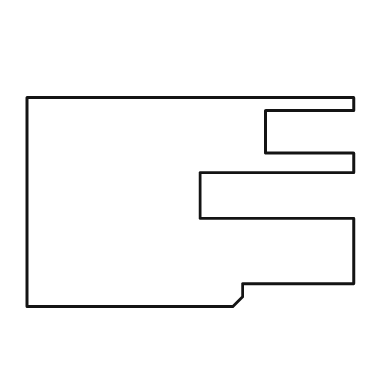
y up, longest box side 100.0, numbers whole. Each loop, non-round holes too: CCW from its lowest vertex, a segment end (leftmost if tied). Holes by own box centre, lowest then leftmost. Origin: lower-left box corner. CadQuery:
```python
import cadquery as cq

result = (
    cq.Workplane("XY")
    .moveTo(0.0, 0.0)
    .lineTo(63.0, 0.0)
    .lineTo(66.0, 3.0)
    .lineTo(66.0, 7.0)
    .lineTo(100.0, 7.0)
    .lineTo(100.0, 27.0)
    .lineTo(53.0, 27.0)
    .lineTo(53.0, 41.0)
    .lineTo(100.0, 41.0)
    .lineTo(100.0, 47.0)
    .lineTo(73.0, 47.0)
    .lineTo(73.0, 60.0)
    .lineTo(100.0, 60.0)
    .lineTo(100.0, 64.0)
    .lineTo(0.0, 64.0)
    .close()
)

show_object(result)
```